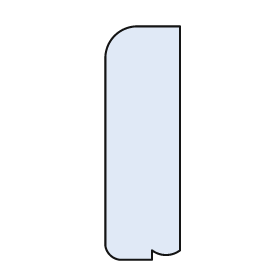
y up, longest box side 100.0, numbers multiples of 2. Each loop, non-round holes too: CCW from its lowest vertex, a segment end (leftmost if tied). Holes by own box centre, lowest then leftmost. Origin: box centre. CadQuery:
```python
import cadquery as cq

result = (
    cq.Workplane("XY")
    .moveTo(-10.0, -50.0)
    .lineTo(4.0, -50.0)
    .lineTo(4.0, -46.0)
    .threePointArc((10.0, -48.0), (16.0, -46.0))
    .lineTo(16.0, 50.0)
    .lineTo(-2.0, 50.0)
    .threePointArc((-12.0, 46.0), (-16.0, 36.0))
    .lineTo(-16.0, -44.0)
    .threePointArc((-14.0, -48.0), (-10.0, -50.0))
    .close()
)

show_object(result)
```